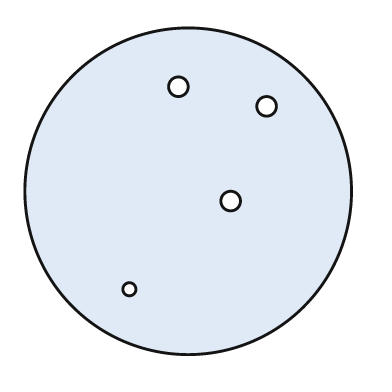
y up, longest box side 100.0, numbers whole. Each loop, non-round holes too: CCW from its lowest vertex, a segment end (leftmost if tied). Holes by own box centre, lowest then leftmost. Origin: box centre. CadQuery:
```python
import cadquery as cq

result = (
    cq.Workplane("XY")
    .moveTo(0.0, 0.0)
    .circle(50.0)
    .moveTo(-18.0, -30.0)
    .circle(2.0)
    .moveTo(13.0, -3.0)
    .circle(3.0)
    .moveTo(24.0, 26.0)
    .circle(3.0)
    .moveTo(-3.0, 32.0)
    .circle(3.0)
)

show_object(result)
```